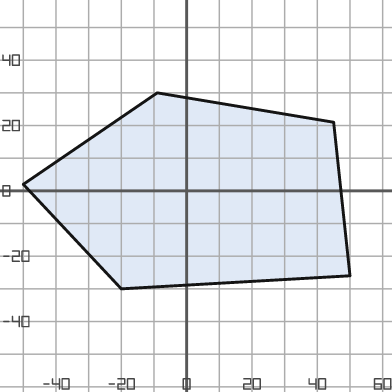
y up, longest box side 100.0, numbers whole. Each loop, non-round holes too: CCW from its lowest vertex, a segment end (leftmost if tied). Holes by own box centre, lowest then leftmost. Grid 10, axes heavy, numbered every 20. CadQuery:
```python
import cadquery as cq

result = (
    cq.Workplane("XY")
    .moveTo(-20.0, -30.0)
    .lineTo(50.0, -26.0)
    .lineTo(45.0, 21.0)
    .lineTo(-9.0, 30.0)
    .lineTo(-50.0, 2.0)
    .close()
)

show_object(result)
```